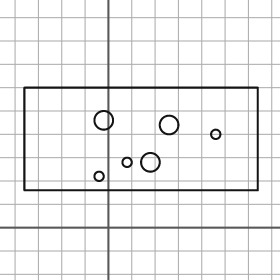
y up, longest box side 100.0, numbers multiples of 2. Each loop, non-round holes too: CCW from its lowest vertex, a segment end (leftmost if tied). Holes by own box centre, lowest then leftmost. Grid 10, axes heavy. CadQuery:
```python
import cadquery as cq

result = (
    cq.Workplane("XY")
    .moveTo(-36.0, 16.0)
    .lineTo(64.0, 16.0)
    .lineTo(64.0, 60.0)
    .lineTo(-36.0, 60.0)
    .close()
    .moveTo(-4.0, 22.0)
    .circle(2.0)
    .moveTo(8.0, 28.0)
    .circle(2.0)
    .moveTo(18.0, 28.0)
    .circle(4.0)
    .moveTo(46.0, 40.0)
    .circle(2.0)
    .moveTo(26.0, 44.0)
    .circle(4.0)
    .moveTo(-2.0, 46.0)
    .circle(4.0)
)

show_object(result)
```